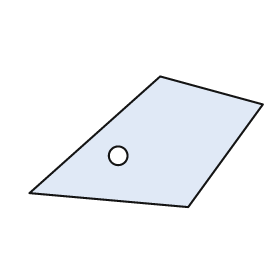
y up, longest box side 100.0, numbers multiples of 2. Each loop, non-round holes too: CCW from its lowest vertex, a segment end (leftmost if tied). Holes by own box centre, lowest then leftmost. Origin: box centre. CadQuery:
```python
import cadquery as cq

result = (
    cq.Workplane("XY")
    .moveTo(18.0, -28.0)
    .lineTo(50.0, 16.0)
    .lineTo(6.0, 28.0)
    .lineTo(-50.0, -22.0)
    .close()
    .moveTo(-12.0, -6.0)
    .circle(4.0)
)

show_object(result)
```